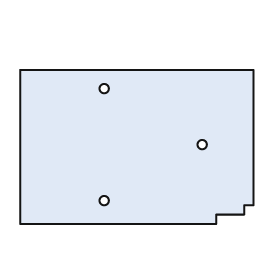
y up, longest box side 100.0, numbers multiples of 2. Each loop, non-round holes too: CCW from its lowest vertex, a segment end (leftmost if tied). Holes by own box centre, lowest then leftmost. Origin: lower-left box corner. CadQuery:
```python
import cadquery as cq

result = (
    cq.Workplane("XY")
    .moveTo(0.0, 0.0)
    .lineTo(84.0, 0.0)
    .lineTo(84.0, 4.0)
    .lineTo(96.0, 4.0)
    .lineTo(96.0, 8.0)
    .lineTo(100.0, 8.0)
    .lineTo(100.0, 66.0)
    .lineTo(0.0, 66.0)
    .close()
    .moveTo(36.0, 10.0)
    .circle(2.0)
    .moveTo(78.0, 34.0)
    .circle(2.0)
    .moveTo(36.0, 58.0)
    .circle(2.0)
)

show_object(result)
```